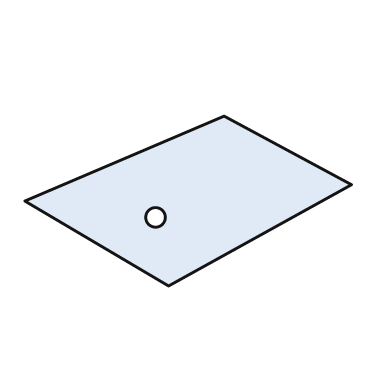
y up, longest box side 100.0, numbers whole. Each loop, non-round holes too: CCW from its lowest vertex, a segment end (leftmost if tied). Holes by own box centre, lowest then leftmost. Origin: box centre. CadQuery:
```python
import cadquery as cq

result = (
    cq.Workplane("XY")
    .moveTo(-6.0, -26.0)
    .lineTo(50.0, 5.0)
    .lineTo(11.0, 26.0)
    .lineTo(-50.0, 0.0)
    .close()
    .moveTo(-10.0, -5.0)
    .circle(3.0)
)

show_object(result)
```